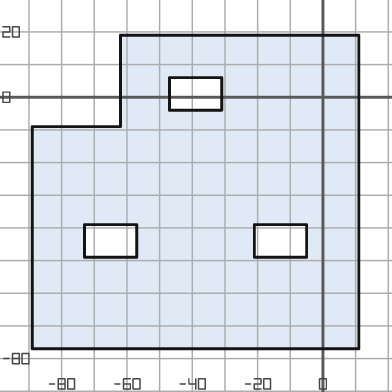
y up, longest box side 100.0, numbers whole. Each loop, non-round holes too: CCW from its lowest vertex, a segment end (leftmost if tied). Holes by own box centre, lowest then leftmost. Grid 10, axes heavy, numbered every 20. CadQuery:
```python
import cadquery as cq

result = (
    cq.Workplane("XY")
    .moveTo(-89.0, -77.0)
    .lineTo(11.0, -77.0)
    .lineTo(11.0, 19.0)
    .lineTo(-62.0, 19.0)
    .lineTo(-62.0, -9.0)
    .lineTo(-89.0, -9.0)
    .close()
    .moveTo(-73.0, -49.0)
    .lineTo(-57.0, -49.0)
    .lineTo(-57.0, -39.0)
    .lineTo(-73.0, -39.0)
    .close()
    .moveTo(-21.0, -49.0)
    .lineTo(-5.0, -49.0)
    .lineTo(-5.0, -39.0)
    .lineTo(-21.0, -39.0)
    .close()
    .moveTo(-47.0, -4.0)
    .lineTo(-31.0, -4.0)
    .lineTo(-31.0, 6.0)
    .lineTo(-47.0, 6.0)
    .close()
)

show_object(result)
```